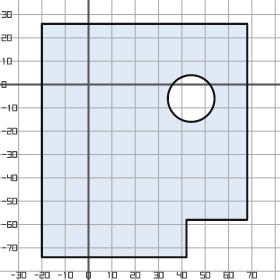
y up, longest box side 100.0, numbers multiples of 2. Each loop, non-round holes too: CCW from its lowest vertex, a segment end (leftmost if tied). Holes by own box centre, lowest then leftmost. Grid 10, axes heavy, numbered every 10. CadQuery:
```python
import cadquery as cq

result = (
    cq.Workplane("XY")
    .moveTo(-20.0, -74.0)
    .lineTo(42.0, -74.0)
    .lineTo(42.0, -58.0)
    .lineTo(68.0, -58.0)
    .lineTo(68.0, 26.0)
    .lineTo(-20.0, 26.0)
    .close()
    .moveTo(44.0, -6.0)
    .circle(10.0)
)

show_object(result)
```